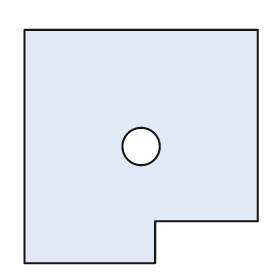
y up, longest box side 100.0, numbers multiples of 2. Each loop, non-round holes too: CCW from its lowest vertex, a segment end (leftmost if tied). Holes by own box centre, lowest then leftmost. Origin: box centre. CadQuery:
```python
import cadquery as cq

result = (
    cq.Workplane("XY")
    .moveTo(-50.0, -50.0)
    .lineTo(6.0, -50.0)
    .lineTo(6.0, -32.0)
    .lineTo(50.0, -32.0)
    .lineTo(50.0, 50.0)
    .lineTo(-50.0, 50.0)
    .close()
    .moveTo(0.0, 0.0)
    .circle(8.0)
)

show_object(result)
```